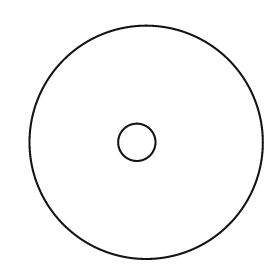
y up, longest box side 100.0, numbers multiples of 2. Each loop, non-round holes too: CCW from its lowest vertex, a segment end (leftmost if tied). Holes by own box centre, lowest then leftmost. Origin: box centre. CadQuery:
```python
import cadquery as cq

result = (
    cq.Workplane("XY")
    .moveTo(0.0, 0.0)
    .circle(50.0)
    .moveTo(-4.0, 0.0)
    .circle(8.0)
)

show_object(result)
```